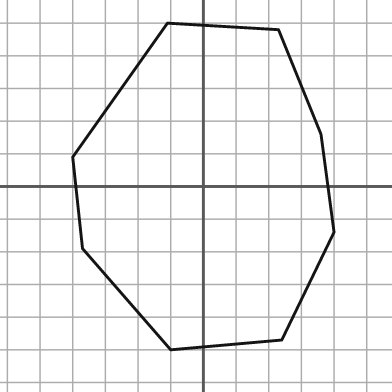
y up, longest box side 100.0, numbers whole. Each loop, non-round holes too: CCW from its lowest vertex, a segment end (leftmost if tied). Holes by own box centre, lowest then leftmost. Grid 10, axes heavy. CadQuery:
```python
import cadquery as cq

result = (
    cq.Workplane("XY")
    .moveTo(-10.0, -50.0)
    .lineTo(24.0, -47.0)
    .lineTo(40.0, -14.0)
    .lineTo(36.0, 16.0)
    .lineTo(23.0, 48.0)
    .lineTo(-11.0, 50.0)
    .lineTo(-40.0, 9.0)
    .lineTo(-37.0, -19.0)
    .close()
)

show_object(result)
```